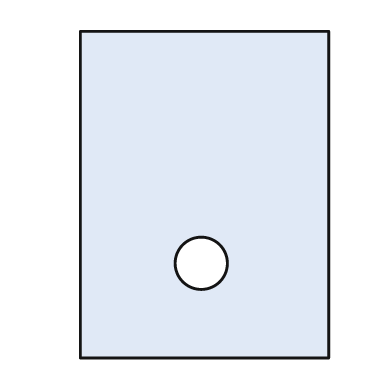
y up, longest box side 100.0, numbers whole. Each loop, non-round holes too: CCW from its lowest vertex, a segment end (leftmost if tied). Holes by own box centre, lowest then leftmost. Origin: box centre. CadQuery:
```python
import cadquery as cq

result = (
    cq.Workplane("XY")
    .moveTo(-38.0, -50.0)
    .lineTo(38.0, -50.0)
    .lineTo(38.0, 50.0)
    .lineTo(-38.0, 50.0)
    .close()
    .moveTo(-1.0, -21.0)
    .circle(8.0)
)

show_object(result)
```